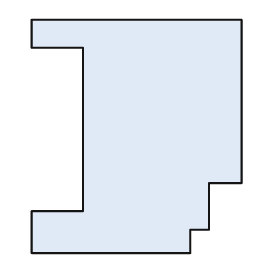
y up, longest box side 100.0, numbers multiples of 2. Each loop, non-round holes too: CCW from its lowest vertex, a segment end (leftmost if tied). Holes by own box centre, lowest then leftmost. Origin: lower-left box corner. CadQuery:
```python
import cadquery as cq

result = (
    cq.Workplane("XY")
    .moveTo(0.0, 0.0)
    .lineTo(68.0, 0.0)
    .lineTo(68.0, 10.0)
    .lineTo(76.0, 10.0)
    .lineTo(76.0, 30.0)
    .lineTo(90.0, 30.0)
    .lineTo(90.0, 100.0)
    .lineTo(0.0, 100.0)
    .lineTo(0.0, 88.0)
    .lineTo(22.0, 88.0)
    .lineTo(22.0, 18.0)
    .lineTo(0.0, 18.0)
    .close()
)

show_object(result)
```